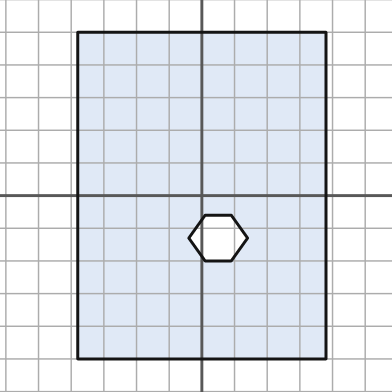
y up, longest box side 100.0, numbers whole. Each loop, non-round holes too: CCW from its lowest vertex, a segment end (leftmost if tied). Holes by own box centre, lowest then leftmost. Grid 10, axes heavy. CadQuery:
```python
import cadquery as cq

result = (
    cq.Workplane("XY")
    .moveTo(-38.0, -50.0)
    .lineTo(38.0, -50.0)
    .lineTo(38.0, 50.0)
    .lineTo(-38.0, 50.0)
    .close()
    .moveTo(1.0, -20.0)
    .lineTo(9.0, -20.0)
    .lineTo(14.0, -13.0)
    .lineTo(9.0, -6.0)
    .lineTo(1.0, -6.0)
    .lineTo(-4.0, -13.0)
    .close()
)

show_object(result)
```